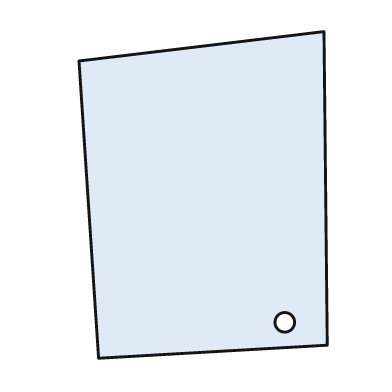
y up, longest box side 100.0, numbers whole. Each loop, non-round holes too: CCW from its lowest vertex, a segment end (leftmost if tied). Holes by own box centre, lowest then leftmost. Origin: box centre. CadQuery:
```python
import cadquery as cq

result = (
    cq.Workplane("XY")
    .moveTo(-32.0, -50.0)
    .lineTo(38.0, -46.0)
    .lineTo(37.0, 50.0)
    .lineTo(-38.0, 41.0)
    .close()
    .moveTo(25.0, -39.0)
    .circle(3.0)
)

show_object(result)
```